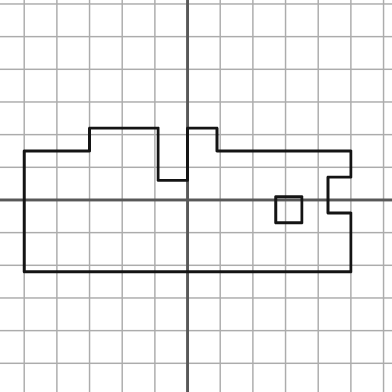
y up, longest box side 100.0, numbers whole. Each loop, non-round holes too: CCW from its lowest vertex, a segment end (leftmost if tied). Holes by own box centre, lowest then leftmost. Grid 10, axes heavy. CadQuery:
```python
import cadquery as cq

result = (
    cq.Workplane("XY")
    .moveTo(-50.0, -22.0)
    .lineTo(50.0, -22.0)
    .lineTo(50.0, -4.0)
    .lineTo(43.0, -4.0)
    .lineTo(43.0, 7.0)
    .lineTo(50.0, 7.0)
    .lineTo(50.0, 15.0)
    .lineTo(9.0, 15.0)
    .lineTo(9.0, 22.0)
    .lineTo(0.0, 22.0)
    .lineTo(0.0, 6.0)
    .lineTo(-9.0, 6.0)
    .lineTo(-9.0, 22.0)
    .lineTo(-30.0, 22.0)
    .lineTo(-30.0, 15.0)
    .lineTo(-50.0, 15.0)
    .close()
    .moveTo(27.0, -7.0)
    .lineTo(35.0, -7.0)
    .lineTo(35.0, 1.0)
    .lineTo(27.0, 1.0)
    .close()
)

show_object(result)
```